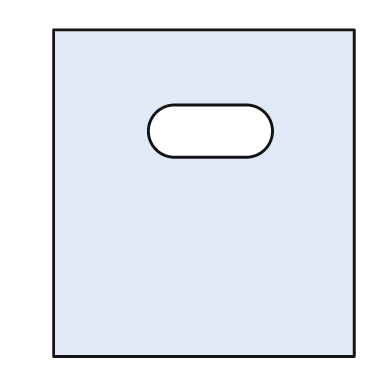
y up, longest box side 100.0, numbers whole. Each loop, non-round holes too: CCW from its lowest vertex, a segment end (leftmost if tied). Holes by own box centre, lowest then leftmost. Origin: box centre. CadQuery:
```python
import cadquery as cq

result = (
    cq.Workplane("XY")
    .moveTo(-46.0, -50.0)
    .lineTo(46.0, -50.0)
    .lineTo(46.0, 50.0)
    .lineTo(-46.0, 50.0)
    .close()
    .moveTo(-9.0, 11.0)
    .lineTo(13.0, 11.0)
    .threePointArc((21.0, 19.0), (13.0, 27.0))
    .lineTo(-9.0, 27.0)
    .threePointArc((-17.0, 19.0), (-9.0, 11.0))
    .close()
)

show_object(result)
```